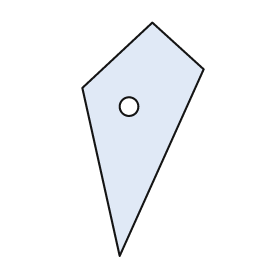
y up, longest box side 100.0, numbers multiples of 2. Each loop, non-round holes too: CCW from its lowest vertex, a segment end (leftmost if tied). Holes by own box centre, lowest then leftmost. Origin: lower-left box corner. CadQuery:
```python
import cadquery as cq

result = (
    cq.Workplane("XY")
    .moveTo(16.0, 0.0)
    .lineTo(52.0, 80.0)
    .lineTo(30.0, 100.0)
    .lineTo(0.0, 72.0)
    .close()
    .moveTo(20.0, 64.0)
    .circle(4.0)
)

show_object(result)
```